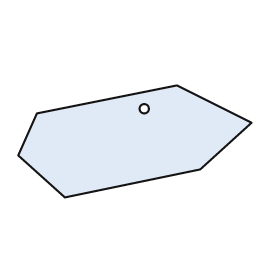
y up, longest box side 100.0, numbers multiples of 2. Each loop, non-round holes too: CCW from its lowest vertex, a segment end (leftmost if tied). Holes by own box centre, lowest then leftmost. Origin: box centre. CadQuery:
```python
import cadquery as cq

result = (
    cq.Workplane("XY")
    .moveTo(-30.0, -24.0)
    .lineTo(28.0, -12.0)
    .lineTo(50.0, 8.0)
    .lineTo(18.0, 24.0)
    .lineTo(-42.0, 12.0)
    .lineTo(-50.0, -6.0)
    .close()
    .moveTo(4.0, 14.0)
    .circle(2.0)
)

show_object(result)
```